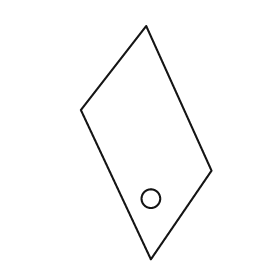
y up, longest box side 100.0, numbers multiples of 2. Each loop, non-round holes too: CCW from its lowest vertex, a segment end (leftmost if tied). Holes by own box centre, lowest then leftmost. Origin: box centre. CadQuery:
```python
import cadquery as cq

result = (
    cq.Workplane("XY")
    .moveTo(2.0, -50.0)
    .lineTo(28.0, -12.0)
    .lineTo(0.0, 50.0)
    .lineTo(-28.0, 14.0)
    .close()
    .moveTo(2.0, -24.0)
    .circle(4.0)
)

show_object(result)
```